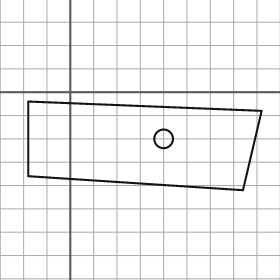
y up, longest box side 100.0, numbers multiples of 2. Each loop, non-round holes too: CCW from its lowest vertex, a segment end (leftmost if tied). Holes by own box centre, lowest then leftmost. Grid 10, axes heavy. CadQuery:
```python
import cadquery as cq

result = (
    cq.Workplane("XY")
    .moveTo(74.0, -42.0)
    .lineTo(82.0, -8.0)
    .lineTo(-18.0, -4.0)
    .lineTo(-18.0, -36.0)
    .close()
    .moveTo(40.0, -20.0)
    .circle(4.0)
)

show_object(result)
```